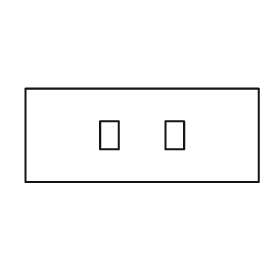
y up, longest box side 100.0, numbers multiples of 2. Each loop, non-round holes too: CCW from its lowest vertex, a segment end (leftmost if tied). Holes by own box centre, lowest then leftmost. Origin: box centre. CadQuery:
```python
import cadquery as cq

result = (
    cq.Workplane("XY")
    .moveTo(-50.0, -20.0)
    .lineTo(50.0, -20.0)
    .lineTo(50.0, 20.0)
    .lineTo(-50.0, 20.0)
    .close()
    .moveTo(-18.0, -6.0)
    .lineTo(-10.0, -6.0)
    .lineTo(-10.0, 6.0)
    .lineTo(-18.0, 6.0)
    .close()
    .moveTo(10.0, -6.0)
    .lineTo(18.0, -6.0)
    .lineTo(18.0, 6.0)
    .lineTo(10.0, 6.0)
    .close()
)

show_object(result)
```